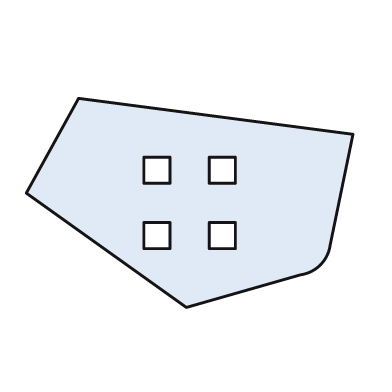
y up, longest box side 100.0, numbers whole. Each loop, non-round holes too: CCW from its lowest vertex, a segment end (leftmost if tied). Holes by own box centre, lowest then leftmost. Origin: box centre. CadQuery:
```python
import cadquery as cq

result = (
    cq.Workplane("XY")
    .moveTo(-1.0, -32.0)
    .lineTo(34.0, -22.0)
    .threePointArc((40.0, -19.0), (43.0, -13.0))
    .lineTo(50.0, 21.0)
    .lineTo(-34.0, 32.0)
    .lineTo(-50.0, 3.0)
    .close()
    .moveTo(-14.0, -14.0)
    .lineTo(-6.0, -14.0)
    .lineTo(-6.0, -6.0)
    .lineTo(-14.0, -6.0)
    .close()
    .moveTo(6.0, -14.0)
    .lineTo(14.0, -14.0)
    .lineTo(14.0, -6.0)
    .lineTo(6.0, -6.0)
    .close()
    .moveTo(-14.0, 6.0)
    .lineTo(-6.0, 6.0)
    .lineTo(-6.0, 14.0)
    .lineTo(-14.0, 14.0)
    .close()
    .moveTo(6.0, 6.0)
    .lineTo(14.0, 6.0)
    .lineTo(14.0, 14.0)
    .lineTo(6.0, 14.0)
    .close()
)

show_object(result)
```